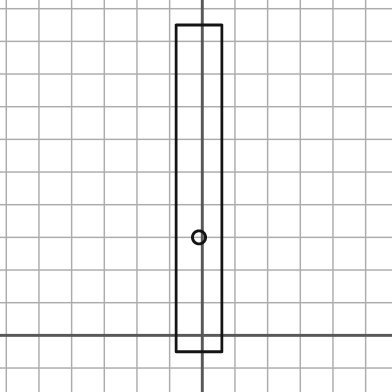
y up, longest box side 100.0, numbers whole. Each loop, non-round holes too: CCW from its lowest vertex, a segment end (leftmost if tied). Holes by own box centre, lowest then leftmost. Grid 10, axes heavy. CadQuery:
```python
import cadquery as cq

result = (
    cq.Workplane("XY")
    .moveTo(-8.0, -5.0)
    .lineTo(6.0, -5.0)
    .lineTo(6.0, 95.0)
    .lineTo(-8.0, 95.0)
    .close()
    .moveTo(-1.0, 30.0)
    .circle(2.0)
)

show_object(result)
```